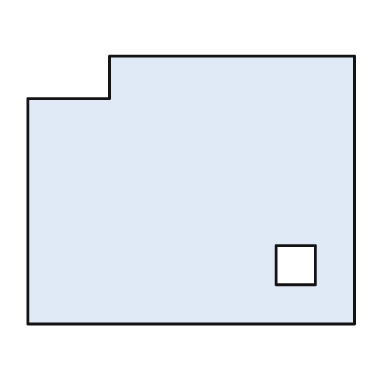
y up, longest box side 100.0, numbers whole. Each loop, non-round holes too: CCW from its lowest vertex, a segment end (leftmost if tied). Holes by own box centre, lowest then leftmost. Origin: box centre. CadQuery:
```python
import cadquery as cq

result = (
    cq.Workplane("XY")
    .moveTo(-50.0, -41.0)
    .lineTo(50.0, -41.0)
    .lineTo(50.0, 41.0)
    .lineTo(-25.0, 41.0)
    .lineTo(-25.0, 28.0)
    .lineTo(-50.0, 28.0)
    .close()
    .moveTo(26.0, -29.0)
    .lineTo(38.0, -29.0)
    .lineTo(38.0, -17.0)
    .lineTo(26.0, -17.0)
    .close()
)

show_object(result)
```